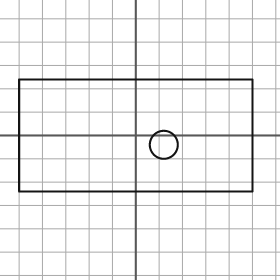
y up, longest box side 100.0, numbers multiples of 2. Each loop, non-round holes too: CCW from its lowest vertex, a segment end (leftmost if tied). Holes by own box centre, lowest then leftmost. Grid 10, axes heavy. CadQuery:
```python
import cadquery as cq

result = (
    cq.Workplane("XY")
    .moveTo(-50.0, -24.0)
    .lineTo(50.0, -24.0)
    .lineTo(50.0, 24.0)
    .lineTo(-50.0, 24.0)
    .close()
    .moveTo(12.0, -4.0)
    .circle(6.0)
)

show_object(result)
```